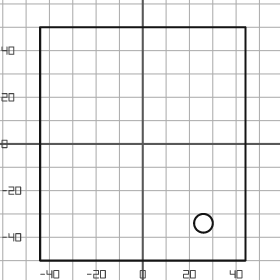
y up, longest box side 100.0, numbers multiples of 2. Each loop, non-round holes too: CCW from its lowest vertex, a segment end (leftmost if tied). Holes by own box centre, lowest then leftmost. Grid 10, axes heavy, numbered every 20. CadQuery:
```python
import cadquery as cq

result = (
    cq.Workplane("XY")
    .moveTo(-44.0, -50.0)
    .lineTo(44.0, -50.0)
    .lineTo(44.0, 50.0)
    .lineTo(-44.0, 50.0)
    .close()
    .moveTo(26.0, -34.0)
    .circle(4.0)
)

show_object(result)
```